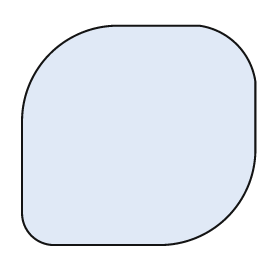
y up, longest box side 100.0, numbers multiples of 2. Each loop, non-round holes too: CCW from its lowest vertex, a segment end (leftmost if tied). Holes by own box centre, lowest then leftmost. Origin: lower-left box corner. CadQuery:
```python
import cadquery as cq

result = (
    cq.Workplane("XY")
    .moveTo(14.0, 0.0)
    .lineTo(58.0, 0.0)
    .threePointArc((88.0, 12.0), (100.0, 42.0))
    .lineTo(100.0, 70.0)
    .threePointArc((92.0, 86.0), (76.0, 94.0))
    .lineTo(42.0, 94.0)
    .threePointArc((12.0, 82.0), (0.0, 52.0))
    .lineTo(0.0, 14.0)
    .threePointArc((4.0, 4.0), (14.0, 0.0))
    .close()
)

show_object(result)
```